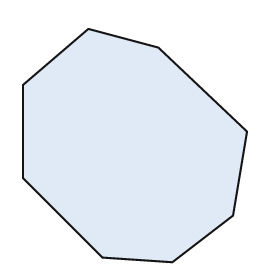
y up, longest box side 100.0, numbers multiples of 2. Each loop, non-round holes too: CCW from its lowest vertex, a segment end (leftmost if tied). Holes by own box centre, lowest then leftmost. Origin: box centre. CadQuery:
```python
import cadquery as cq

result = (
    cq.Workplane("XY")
    .moveTo(16.0, -50.0)
    .lineTo(42.0, -30.0)
    .lineTo(48.0, 6.0)
    .lineTo(10.0, 42.0)
    .lineTo(-20.0, 50.0)
    .lineTo(-48.0, 26.0)
    .lineTo(-48.0, -14.0)
    .lineTo(-14.0, -48.0)
    .close()
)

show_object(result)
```